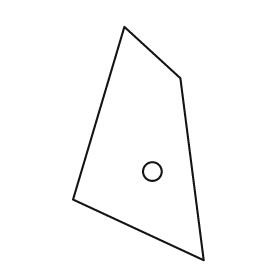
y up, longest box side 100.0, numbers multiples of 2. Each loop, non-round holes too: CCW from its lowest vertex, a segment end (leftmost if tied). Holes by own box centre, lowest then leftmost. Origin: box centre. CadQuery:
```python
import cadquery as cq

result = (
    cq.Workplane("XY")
    .moveTo(28.0, -50.0)
    .lineTo(18.0, 28.0)
    .lineTo(-6.0, 50.0)
    .lineTo(-28.0, -24.0)
    .close()
    .moveTo(6.0, -12.0)
    .circle(4.0)
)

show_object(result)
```